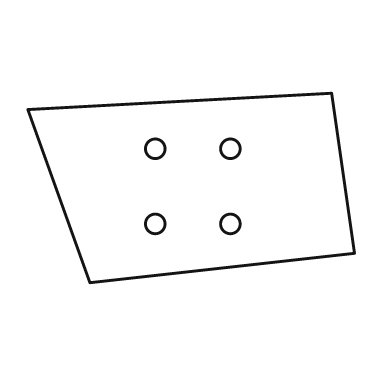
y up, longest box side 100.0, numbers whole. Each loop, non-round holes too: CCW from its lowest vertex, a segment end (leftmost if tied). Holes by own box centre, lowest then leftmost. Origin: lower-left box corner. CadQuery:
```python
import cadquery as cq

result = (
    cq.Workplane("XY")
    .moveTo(19.0, 0.0)
    .lineTo(100.0, 9.0)
    .lineTo(93.0, 58.0)
    .lineTo(0.0, 53.0)
    .close()
    .moveTo(39.0, 18.0)
    .circle(3.0)
    .moveTo(62.0, 18.0)
    .circle(3.0)
    .moveTo(39.0, 41.0)
    .circle(3.0)
    .moveTo(62.0, 41.0)
    .circle(3.0)
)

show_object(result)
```